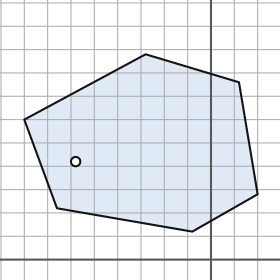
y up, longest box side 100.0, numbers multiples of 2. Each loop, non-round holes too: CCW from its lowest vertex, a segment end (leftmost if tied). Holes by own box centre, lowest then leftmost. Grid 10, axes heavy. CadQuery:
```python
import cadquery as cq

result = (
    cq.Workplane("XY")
    .moveTo(-8.0, 12.0)
    .lineTo(20.0, 28.0)
    .lineTo(12.0, 76.0)
    .lineTo(-28.0, 88.0)
    .lineTo(-80.0, 60.0)
    .lineTo(-66.0, 22.0)
    .close()
    .moveTo(-58.0, 42.0)
    .circle(2.0)
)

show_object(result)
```